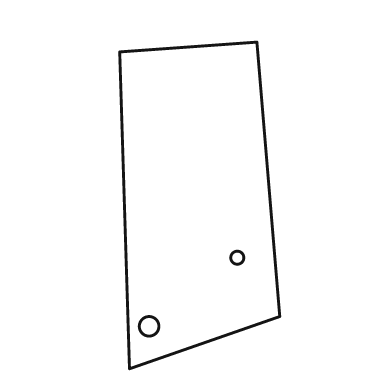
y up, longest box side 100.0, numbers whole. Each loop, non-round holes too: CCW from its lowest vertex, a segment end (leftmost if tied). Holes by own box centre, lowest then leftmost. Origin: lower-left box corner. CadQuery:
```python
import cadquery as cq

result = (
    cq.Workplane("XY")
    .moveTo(3.0, 0.0)
    .lineTo(49.0, 16.0)
    .lineTo(42.0, 100.0)
    .lineTo(0.0, 97.0)
    .close()
    .moveTo(9.0, 13.0)
    .circle(3.0)
    .moveTo(36.0, 34.0)
    .circle(2.0)
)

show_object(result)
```